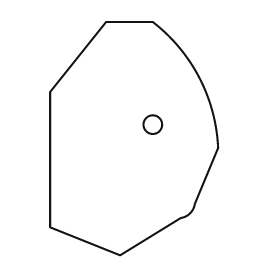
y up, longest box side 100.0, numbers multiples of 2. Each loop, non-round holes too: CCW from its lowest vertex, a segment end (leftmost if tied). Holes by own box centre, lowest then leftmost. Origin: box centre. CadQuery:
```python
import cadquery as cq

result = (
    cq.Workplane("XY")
    .moveTo(-6.0, -50.0)
    .lineTo(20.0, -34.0)
    .threePointArc((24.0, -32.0), (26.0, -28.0))
    .lineTo(36.0, -4.0)
    .threePointArc((28.0, 26.0), (8.0, 50.0))
    .lineTo(-12.0, 50.0)
    .lineTo(-36.0, 20.0)
    .lineTo(-36.0, -38.0)
    .close()
    .moveTo(8.0, 6.0)
    .circle(4.0)
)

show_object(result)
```